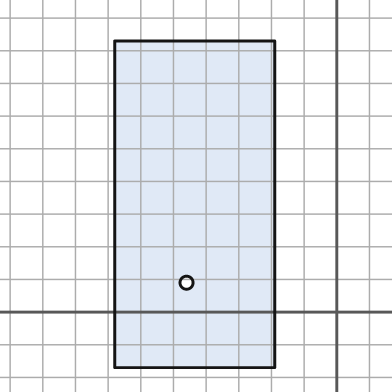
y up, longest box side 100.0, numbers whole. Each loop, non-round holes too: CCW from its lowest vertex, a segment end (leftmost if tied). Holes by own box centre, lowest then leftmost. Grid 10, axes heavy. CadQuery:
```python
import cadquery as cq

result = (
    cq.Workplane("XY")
    .moveTo(-68.0, -17.0)
    .lineTo(-19.0, -17.0)
    .lineTo(-19.0, 83.0)
    .lineTo(-68.0, 83.0)
    .close()
    .moveTo(-46.0, 9.0)
    .circle(2.0)
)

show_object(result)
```